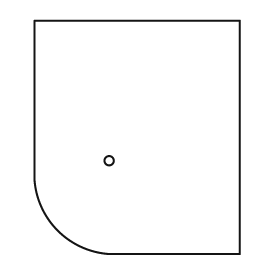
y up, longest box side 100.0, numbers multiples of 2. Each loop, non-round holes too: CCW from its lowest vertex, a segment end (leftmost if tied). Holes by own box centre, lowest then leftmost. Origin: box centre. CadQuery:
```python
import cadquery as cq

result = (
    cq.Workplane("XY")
    .moveTo(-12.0, -50.0)
    .lineTo(44.0, -50.0)
    .lineTo(44.0, 50.0)
    .lineTo(-44.0, 50.0)
    .lineTo(-44.0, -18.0)
    .threePointArc((-34.0, -40.0), (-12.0, -50.0))
    .close()
    .moveTo(-12.0, -10.0)
    .circle(2.0)
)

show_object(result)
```